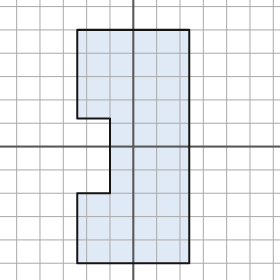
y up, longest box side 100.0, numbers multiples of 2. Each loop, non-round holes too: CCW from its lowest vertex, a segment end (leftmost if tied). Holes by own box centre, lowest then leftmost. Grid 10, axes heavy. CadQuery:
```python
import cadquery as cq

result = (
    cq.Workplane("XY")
    .moveTo(-24.0, -50.0)
    .lineTo(24.0, -50.0)
    .lineTo(24.0, 50.0)
    .lineTo(-24.0, 50.0)
    .lineTo(-24.0, 12.0)
    .lineTo(-10.0, 12.0)
    .lineTo(-10.0, -20.0)
    .lineTo(-24.0, -20.0)
    .close()
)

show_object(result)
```